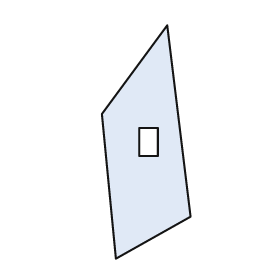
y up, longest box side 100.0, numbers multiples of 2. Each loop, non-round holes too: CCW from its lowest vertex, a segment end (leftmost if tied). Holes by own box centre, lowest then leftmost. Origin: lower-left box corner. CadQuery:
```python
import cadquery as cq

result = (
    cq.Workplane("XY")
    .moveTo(6.0, 0.0)
    .lineTo(38.0, 18.0)
    .lineTo(28.0, 100.0)
    .lineTo(0.0, 62.0)
    .close()
    .moveTo(16.0, 44.0)
    .lineTo(24.0, 44.0)
    .lineTo(24.0, 56.0)
    .lineTo(16.0, 56.0)
    .close()
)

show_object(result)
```